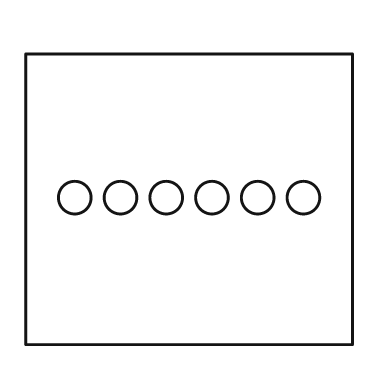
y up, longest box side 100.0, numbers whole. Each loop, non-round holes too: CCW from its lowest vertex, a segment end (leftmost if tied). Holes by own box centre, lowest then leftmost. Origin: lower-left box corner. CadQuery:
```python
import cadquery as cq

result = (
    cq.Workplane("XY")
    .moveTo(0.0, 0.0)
    .lineTo(100.0, 0.0)
    .lineTo(100.0, 89.0)
    .lineTo(0.0, 89.0)
    .close()
    .moveTo(15.0, 45.0)
    .circle(5.0)
    .moveTo(29.0, 45.0)
    .circle(5.0)
    .moveTo(43.0, 45.0)
    .circle(5.0)
    .moveTo(57.0, 45.0)
    .circle(5.0)
    .moveTo(71.0, 45.0)
    .circle(5.0)
    .moveTo(85.0, 45.0)
    .circle(5.0)
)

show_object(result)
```